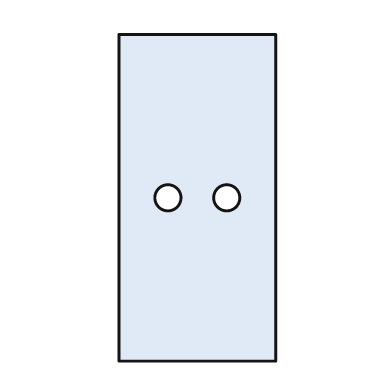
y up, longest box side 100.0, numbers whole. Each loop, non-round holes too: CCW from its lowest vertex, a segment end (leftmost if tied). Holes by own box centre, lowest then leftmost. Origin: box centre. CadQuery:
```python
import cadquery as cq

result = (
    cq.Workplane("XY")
    .moveTo(-24.0, -50.0)
    .lineTo(24.0, -50.0)
    .lineTo(24.0, 50.0)
    .lineTo(-24.0, 50.0)
    .close()
    .moveTo(-9.0, 0.0)
    .circle(4.0)
    .moveTo(9.0, 0.0)
    .circle(4.0)
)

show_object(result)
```